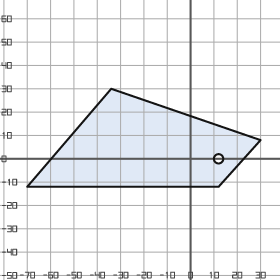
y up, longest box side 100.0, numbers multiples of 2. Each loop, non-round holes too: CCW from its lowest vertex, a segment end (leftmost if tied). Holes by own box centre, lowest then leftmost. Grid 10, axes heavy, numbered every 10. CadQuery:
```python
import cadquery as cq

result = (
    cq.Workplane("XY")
    .moveTo(-70.0, -12.0)
    .lineTo(12.0, -12.0)
    .lineTo(30.0, 8.0)
    .lineTo(-34.0, 30.0)
    .close()
    .moveTo(12.0, 0.0)
    .circle(2.0)
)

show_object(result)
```